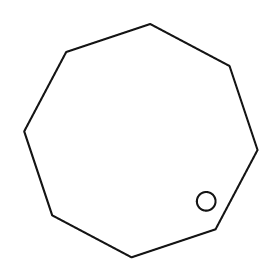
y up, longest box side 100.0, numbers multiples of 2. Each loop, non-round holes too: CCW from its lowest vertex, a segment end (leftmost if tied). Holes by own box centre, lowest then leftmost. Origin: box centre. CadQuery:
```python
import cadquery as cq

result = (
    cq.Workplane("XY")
    .moveTo(-4.0, -50.0)
    .lineTo(32.0, -38.0)
    .lineTo(50.0, -4.0)
    .lineTo(38.0, 32.0)
    .lineTo(4.0, 50.0)
    .lineTo(-32.0, 38.0)
    .lineTo(-50.0, 4.0)
    .lineTo(-38.0, -32.0)
    .close()
    .moveTo(28.0, -26.0)
    .circle(4.0)
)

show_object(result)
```